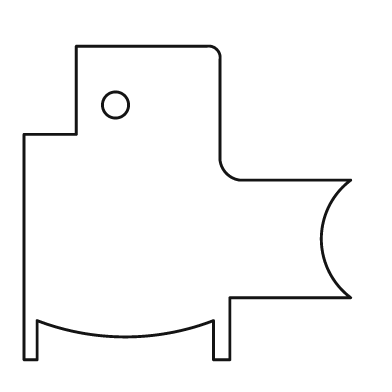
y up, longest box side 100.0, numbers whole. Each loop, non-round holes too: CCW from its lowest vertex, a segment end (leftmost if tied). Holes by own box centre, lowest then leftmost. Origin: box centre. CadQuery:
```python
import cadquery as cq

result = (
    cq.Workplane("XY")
    .moveTo(-50.0, -48.0)
    .lineTo(-46.0, -48.0)
    .lineTo(-46.0, -36.0)
    .threePointArc((-19.0, -41.0), (8.0, -36.0))
    .lineTo(8.0, -48.0)
    .lineTo(13.0, -48.0)
    .lineTo(13.0, -29.0)
    .lineTo(50.0, -29.0)
    .threePointArc((41.0, -11.0), (50.0, 7.0))
    .lineTo(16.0, 7.0)
    .threePointArc((12.0, 9.0), (10.0, 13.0))
    .lineTo(10.0, 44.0)
    .threePointArc((9.0, 47.0), (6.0, 48.0))
    .lineTo(-34.0, 48.0)
    .lineTo(-34.0, 21.0)
    .lineTo(-50.0, 21.0)
    .close()
    .moveTo(-22.0, 30.0)
    .circle(4.0)
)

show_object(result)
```